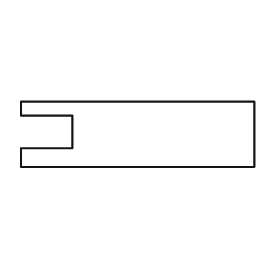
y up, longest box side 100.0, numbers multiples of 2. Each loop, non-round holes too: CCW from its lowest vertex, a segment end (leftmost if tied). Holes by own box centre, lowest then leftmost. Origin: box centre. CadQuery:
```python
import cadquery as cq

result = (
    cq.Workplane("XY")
    .moveTo(-50.0, -14.0)
    .lineTo(50.0, -14.0)
    .lineTo(50.0, 14.0)
    .lineTo(-50.0, 14.0)
    .lineTo(-50.0, 8.0)
    .lineTo(-28.0, 8.0)
    .lineTo(-28.0, -6.0)
    .lineTo(-50.0, -6.0)
    .close()
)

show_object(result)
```